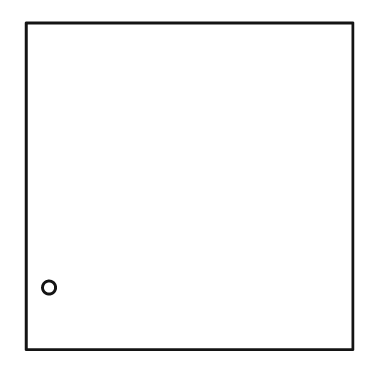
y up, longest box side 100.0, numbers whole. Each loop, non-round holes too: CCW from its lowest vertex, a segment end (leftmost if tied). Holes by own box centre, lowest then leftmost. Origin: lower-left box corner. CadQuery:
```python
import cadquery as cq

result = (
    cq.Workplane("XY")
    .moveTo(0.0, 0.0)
    .lineTo(100.0, 0.0)
    .lineTo(100.0, 100.0)
    .lineTo(0.0, 100.0)
    .close()
    .moveTo(7.0, 19.0)
    .circle(2.0)
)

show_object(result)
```